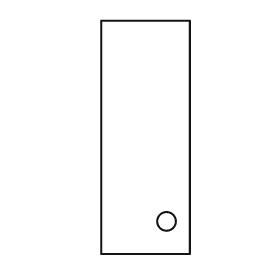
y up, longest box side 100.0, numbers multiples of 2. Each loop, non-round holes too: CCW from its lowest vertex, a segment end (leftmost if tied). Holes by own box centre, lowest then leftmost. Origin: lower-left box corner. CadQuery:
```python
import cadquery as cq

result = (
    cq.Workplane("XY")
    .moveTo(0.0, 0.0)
    .lineTo(38.0, 0.0)
    .lineTo(38.0, 100.0)
    .lineTo(0.0, 100.0)
    .close()
    .moveTo(28.0, 14.0)
    .circle(4.0)
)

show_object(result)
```